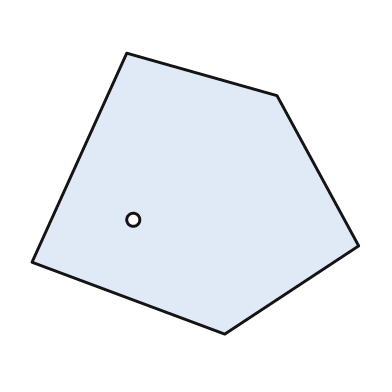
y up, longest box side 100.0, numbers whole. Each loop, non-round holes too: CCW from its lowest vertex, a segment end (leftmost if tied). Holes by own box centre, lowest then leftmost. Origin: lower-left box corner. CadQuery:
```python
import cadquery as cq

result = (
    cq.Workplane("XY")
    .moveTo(59.0, 0.0)
    .lineTo(100.0, 27.0)
    .lineTo(75.0, 73.0)
    .lineTo(29.0, 86.0)
    .lineTo(0.0, 22.0)
    .close()
    .moveTo(31.0, 35.0)
    .circle(2.0)
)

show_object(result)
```